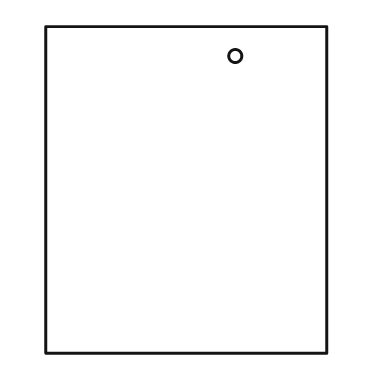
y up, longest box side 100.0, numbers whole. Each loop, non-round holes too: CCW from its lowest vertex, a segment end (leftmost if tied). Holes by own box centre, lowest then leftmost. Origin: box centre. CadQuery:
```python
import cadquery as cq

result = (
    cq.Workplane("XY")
    .moveTo(-43.0, -50.0)
    .lineTo(43.0, -50.0)
    .lineTo(43.0, 50.0)
    .lineTo(-43.0, 50.0)
    .close()
    .moveTo(15.0, 41.0)
    .circle(2.0)
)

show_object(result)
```